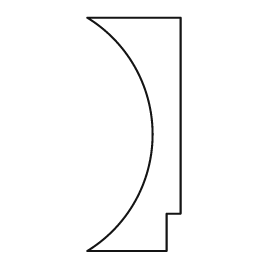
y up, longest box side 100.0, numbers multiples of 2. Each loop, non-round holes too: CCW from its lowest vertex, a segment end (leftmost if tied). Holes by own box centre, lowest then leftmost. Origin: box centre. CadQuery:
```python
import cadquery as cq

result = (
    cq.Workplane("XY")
    .moveTo(-20.0, -50.0)
    .lineTo(14.0, -50.0)
    .lineTo(14.0, -34.0)
    .lineTo(20.0, -34.0)
    .lineTo(20.0, 50.0)
    .lineTo(-20.0, 50.0)
    .threePointArc((8.0, 0.0), (-20.0, -50.0))
    .close()
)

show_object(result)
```